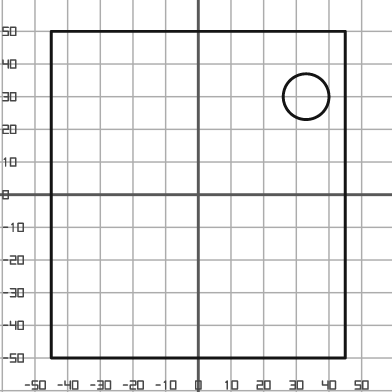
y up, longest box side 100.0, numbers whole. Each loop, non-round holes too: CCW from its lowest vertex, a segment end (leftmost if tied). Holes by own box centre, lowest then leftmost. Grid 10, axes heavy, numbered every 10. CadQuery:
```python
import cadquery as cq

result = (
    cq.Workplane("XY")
    .moveTo(-45.0, -50.0)
    .lineTo(45.0, -50.0)
    .lineTo(45.0, 50.0)
    .lineTo(-45.0, 50.0)
    .close()
    .moveTo(33.0, 30.0)
    .circle(7.0)
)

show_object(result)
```